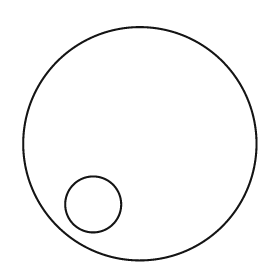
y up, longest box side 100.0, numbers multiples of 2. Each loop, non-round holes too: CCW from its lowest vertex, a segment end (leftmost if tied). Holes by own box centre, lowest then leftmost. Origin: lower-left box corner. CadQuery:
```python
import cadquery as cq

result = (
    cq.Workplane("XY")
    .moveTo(50.0, 50.0)
    .circle(50.0)
    .moveTo(30.0, 24.0)
    .circle(12.0)
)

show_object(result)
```